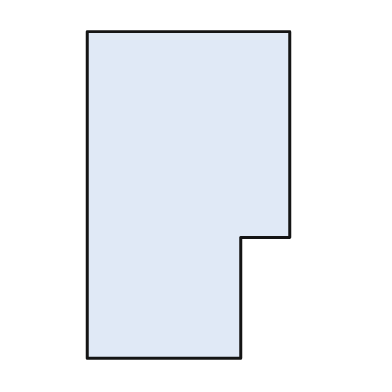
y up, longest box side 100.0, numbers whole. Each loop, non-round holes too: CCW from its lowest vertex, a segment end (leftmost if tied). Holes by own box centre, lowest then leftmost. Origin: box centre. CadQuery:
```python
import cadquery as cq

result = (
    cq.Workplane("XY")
    .moveTo(-31.0, -50.0)
    .lineTo(16.0, -50.0)
    .lineTo(16.0, -13.0)
    .lineTo(31.0, -13.0)
    .lineTo(31.0, 50.0)
    .lineTo(-31.0, 50.0)
    .close()
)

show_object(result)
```